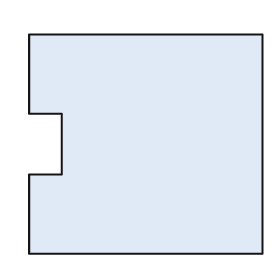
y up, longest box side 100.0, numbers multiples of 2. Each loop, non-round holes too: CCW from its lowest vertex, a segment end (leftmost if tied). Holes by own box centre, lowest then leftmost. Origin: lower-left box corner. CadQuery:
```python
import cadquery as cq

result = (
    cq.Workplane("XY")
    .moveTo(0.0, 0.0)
    .lineTo(100.0, 0.0)
    .lineTo(100.0, 94.0)
    .lineTo(0.0, 94.0)
    .lineTo(0.0, 60.0)
    .lineTo(14.0, 60.0)
    .lineTo(14.0, 34.0)
    .lineTo(0.0, 34.0)
    .close()
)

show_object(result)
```